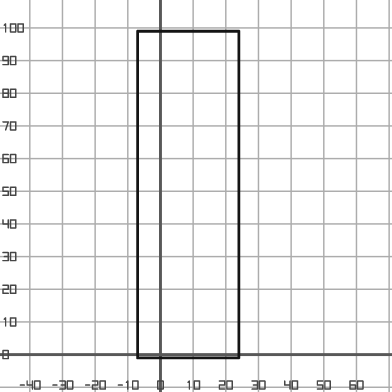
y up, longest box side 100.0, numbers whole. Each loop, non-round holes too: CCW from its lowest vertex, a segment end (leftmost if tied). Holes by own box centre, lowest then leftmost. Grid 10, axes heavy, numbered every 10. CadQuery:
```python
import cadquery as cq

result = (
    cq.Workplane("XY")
    .moveTo(-7.0, -1.0)
    .lineTo(24.0, -1.0)
    .lineTo(24.0, 99.0)
    .lineTo(-7.0, 99.0)
    .close()
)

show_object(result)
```